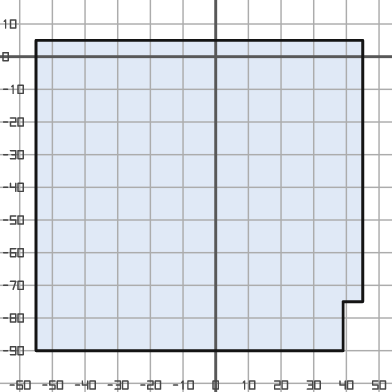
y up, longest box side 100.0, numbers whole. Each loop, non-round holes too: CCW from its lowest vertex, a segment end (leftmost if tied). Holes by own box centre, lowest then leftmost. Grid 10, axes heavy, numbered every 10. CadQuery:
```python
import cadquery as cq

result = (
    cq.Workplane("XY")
    .moveTo(-55.0, -90.0)
    .lineTo(39.0, -90.0)
    .lineTo(39.0, -75.0)
    .lineTo(45.0, -75.0)
    .lineTo(45.0, 5.0)
    .lineTo(-55.0, 5.0)
    .close()
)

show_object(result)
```